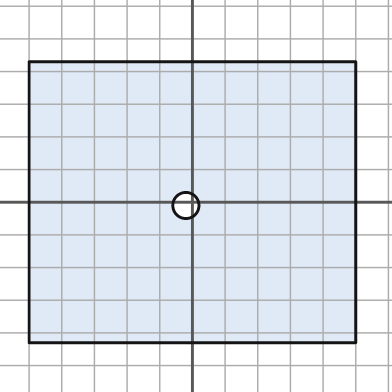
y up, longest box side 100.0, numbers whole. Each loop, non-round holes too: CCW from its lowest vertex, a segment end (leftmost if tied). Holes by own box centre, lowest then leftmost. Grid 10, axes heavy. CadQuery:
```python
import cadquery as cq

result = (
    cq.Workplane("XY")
    .moveTo(-50.0, -43.0)
    .lineTo(50.0, -43.0)
    .lineTo(50.0, 43.0)
    .lineTo(-50.0, 43.0)
    .close()
    .moveTo(-2.0, -1.0)
    .circle(4.0)
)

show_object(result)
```